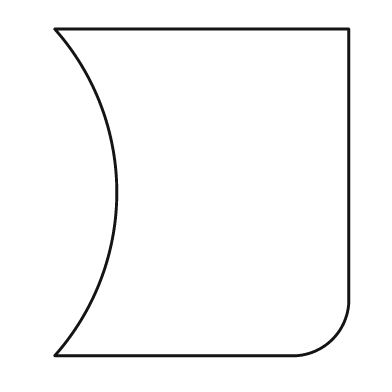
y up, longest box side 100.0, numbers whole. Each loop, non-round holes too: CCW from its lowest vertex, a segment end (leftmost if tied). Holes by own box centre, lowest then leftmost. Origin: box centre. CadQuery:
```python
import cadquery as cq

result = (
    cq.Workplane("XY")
    .moveTo(-45.0, -50.0)
    .lineTo(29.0, -50.0)
    .threePointArc((40.0, -45.0), (45.0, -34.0))
    .lineTo(45.0, 50.0)
    .lineTo(-45.0, 50.0)
    .threePointArc((-26.0, 0.0), (-45.0, -50.0))
    .close()
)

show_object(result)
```